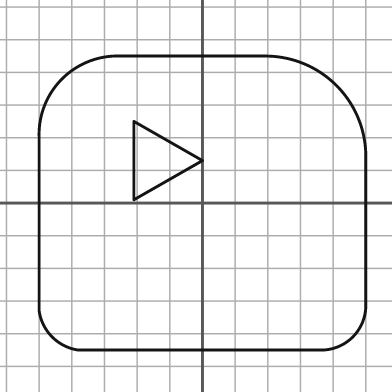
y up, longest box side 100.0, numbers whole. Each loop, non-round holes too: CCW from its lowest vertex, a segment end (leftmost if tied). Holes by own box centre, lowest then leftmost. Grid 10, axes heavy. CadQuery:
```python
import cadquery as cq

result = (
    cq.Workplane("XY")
    .moveTo(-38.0, -45.0)
    .lineTo(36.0, -45.0)
    .threePointArc((46.0, -41.0), (50.0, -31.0))
    .lineTo(50.0, 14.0)
    .threePointArc((41.0, 36.0), (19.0, 45.0))
    .lineTo(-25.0, 45.0)
    .threePointArc((-43.0, 38.0), (-50.0, 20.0))
    .lineTo(-50.0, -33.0)
    .threePointArc((-46.0, -41.0), (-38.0, -45.0))
    .close()
    .moveTo(-21.0, 1.0)
    .lineTo(0.0, 13.0)
    .lineTo(-21.0, 25.0)
    .close()
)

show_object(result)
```